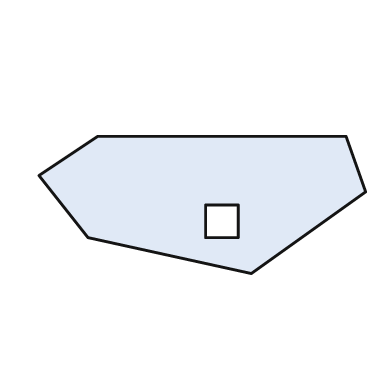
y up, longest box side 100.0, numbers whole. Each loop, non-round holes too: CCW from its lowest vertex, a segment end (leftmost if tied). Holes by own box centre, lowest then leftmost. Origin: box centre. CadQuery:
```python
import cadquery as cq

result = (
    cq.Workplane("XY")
    .moveTo(15.0, -21.0)
    .lineTo(50.0, 4.0)
    .lineTo(44.0, 21.0)
    .lineTo(-32.0, 21.0)
    .lineTo(-50.0, 9.0)
    .lineTo(-35.0, -10.0)
    .close()
    .moveTo(1.0, -10.0)
    .lineTo(11.0, -10.0)
    .lineTo(11.0, 0.0)
    .lineTo(1.0, 0.0)
    .close()
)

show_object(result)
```